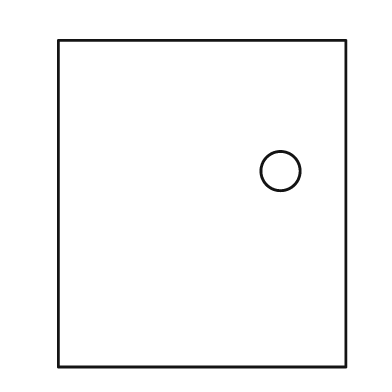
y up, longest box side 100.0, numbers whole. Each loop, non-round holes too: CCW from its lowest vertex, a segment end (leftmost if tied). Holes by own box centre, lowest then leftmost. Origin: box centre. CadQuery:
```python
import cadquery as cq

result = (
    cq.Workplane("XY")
    .moveTo(-44.0, -50.0)
    .lineTo(44.0, -50.0)
    .lineTo(44.0, 50.0)
    .lineTo(-44.0, 50.0)
    .close()
    .moveTo(24.0, 10.0)
    .circle(6.0)
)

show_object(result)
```